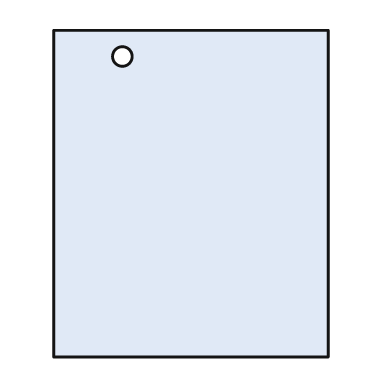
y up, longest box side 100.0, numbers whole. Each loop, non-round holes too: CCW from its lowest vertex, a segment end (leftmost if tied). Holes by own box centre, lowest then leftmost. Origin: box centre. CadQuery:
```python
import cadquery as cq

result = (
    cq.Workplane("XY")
    .moveTo(-42.0, -50.0)
    .lineTo(42.0, -50.0)
    .lineTo(42.0, 50.0)
    .lineTo(-42.0, 50.0)
    .close()
    .moveTo(-21.0, 42.0)
    .circle(3.0)
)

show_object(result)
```